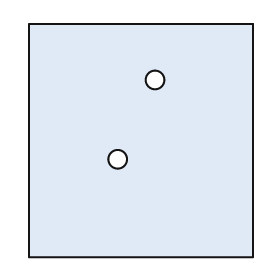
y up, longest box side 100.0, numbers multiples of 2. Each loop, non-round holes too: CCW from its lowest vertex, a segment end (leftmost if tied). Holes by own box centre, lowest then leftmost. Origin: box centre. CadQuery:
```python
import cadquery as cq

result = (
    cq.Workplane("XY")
    .moveTo(-48.0, -50.0)
    .lineTo(48.0, -50.0)
    .lineTo(48.0, 50.0)
    .lineTo(-48.0, 50.0)
    .close()
    .moveTo(-10.0, -8.0)
    .circle(4.0)
    .moveTo(6.0, 26.0)
    .circle(4.0)
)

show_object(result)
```